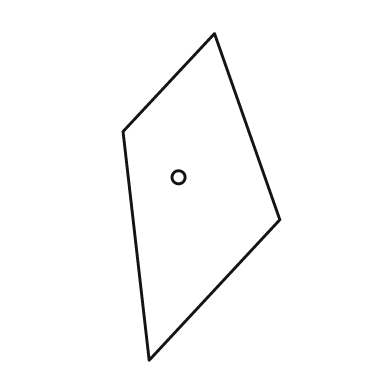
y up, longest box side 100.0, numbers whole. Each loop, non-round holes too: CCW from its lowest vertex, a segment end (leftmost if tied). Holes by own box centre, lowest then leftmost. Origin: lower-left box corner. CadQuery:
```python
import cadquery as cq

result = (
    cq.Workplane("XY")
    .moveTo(8.0, 0.0)
    .lineTo(48.0, 43.0)
    .lineTo(28.0, 100.0)
    .lineTo(0.0, 70.0)
    .close()
    .moveTo(17.0, 56.0)
    .circle(2.0)
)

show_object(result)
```